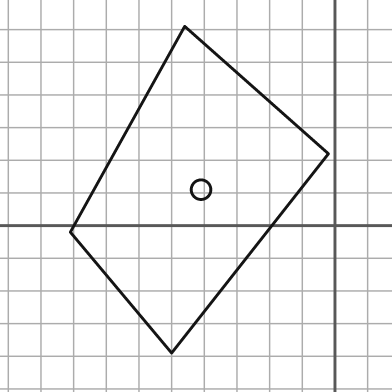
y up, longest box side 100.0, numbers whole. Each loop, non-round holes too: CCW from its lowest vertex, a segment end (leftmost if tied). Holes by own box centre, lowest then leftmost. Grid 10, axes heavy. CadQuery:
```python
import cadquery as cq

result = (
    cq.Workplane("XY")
    .moveTo(-50.0, -39.0)
    .lineTo(-2.0, 22.0)
    .lineTo(-46.0, 61.0)
    .lineTo(-81.0, -2.0)
    .close()
    .moveTo(-41.0, 11.0)
    .circle(3.0)
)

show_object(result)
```